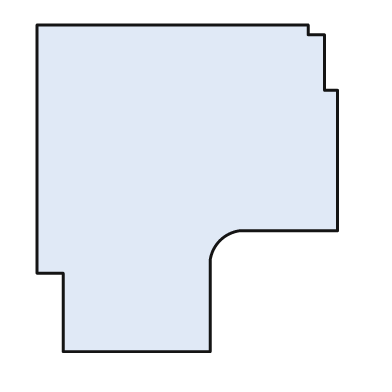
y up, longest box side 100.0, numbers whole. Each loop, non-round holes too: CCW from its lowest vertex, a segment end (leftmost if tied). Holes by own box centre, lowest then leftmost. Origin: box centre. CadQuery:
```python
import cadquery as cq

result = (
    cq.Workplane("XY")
    .moveTo(-38.0, -50.0)
    .lineTo(7.0, -50.0)
    .lineTo(7.0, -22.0)
    .threePointArc((10.0, -16.0), (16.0, -13.0))
    .lineTo(46.0, -13.0)
    .lineTo(46.0, 30.0)
    .lineTo(42.0, 30.0)
    .lineTo(42.0, 47.0)
    .lineTo(37.0, 47.0)
    .lineTo(37.0, 50.0)
    .lineTo(-46.0, 50.0)
    .lineTo(-46.0, -26.0)
    .lineTo(-38.0, -26.0)
    .close()
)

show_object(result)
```